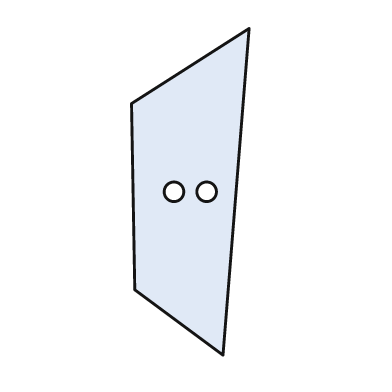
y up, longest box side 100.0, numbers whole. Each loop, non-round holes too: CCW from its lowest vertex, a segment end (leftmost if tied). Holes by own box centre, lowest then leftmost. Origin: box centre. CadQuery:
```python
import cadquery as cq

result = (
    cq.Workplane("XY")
    .moveTo(10.0, -50.0)
    .lineTo(18.0, 50.0)
    .lineTo(-18.0, 27.0)
    .lineTo(-17.0, -30.0)
    .close()
    .moveTo(-5.0, 0.0)
    .circle(3.0)
    .moveTo(5.0, 0.0)
    .circle(3.0)
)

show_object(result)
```